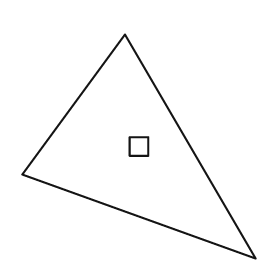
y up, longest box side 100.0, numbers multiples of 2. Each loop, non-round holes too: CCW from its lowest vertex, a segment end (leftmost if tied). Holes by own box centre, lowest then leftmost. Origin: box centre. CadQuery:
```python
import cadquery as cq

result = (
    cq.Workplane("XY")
    .moveTo(50.0, -48.0)
    .lineTo(-6.0, 48.0)
    .lineTo(-50.0, -12.0)
    .close()
    .moveTo(-4.0, -4.0)
    .lineTo(4.0, -4.0)
    .lineTo(4.0, 4.0)
    .lineTo(-4.0, 4.0)
    .close()
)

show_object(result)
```